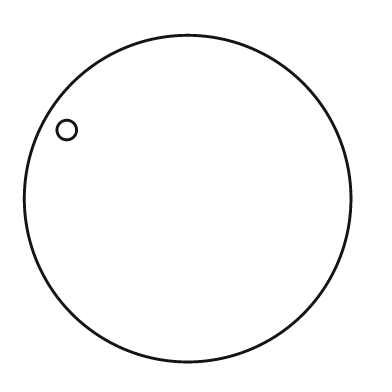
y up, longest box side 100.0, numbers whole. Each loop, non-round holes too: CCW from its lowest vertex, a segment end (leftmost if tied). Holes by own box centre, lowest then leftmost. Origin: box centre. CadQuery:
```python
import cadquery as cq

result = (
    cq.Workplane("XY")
    .moveTo(0.0, 0.0)
    .circle(50.0)
    .moveTo(-37.0, 21.0)
    .circle(3.0)
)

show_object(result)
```